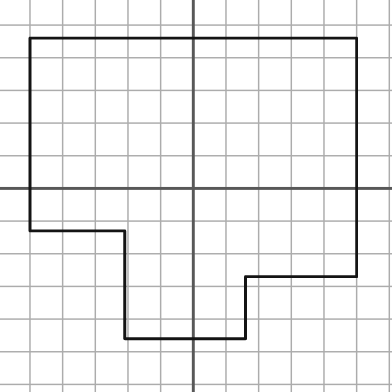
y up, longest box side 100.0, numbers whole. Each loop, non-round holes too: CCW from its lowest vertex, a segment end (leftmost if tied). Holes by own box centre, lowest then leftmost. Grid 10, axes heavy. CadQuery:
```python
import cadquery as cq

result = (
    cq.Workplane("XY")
    .moveTo(-21.0, -46.0)
    .lineTo(16.0, -46.0)
    .lineTo(16.0, -27.0)
    .lineTo(50.0, -27.0)
    .lineTo(50.0, 46.0)
    .lineTo(-50.0, 46.0)
    .lineTo(-50.0, -13.0)
    .lineTo(-21.0, -13.0)
    .close()
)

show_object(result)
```